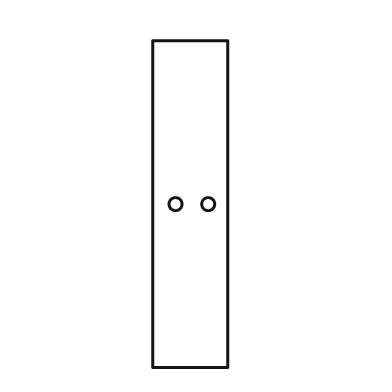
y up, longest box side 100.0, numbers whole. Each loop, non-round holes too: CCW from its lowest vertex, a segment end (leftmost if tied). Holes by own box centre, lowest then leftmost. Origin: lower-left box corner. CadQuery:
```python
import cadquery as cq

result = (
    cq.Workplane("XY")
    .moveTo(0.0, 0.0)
    .lineTo(23.0, 0.0)
    .lineTo(23.0, 100.0)
    .lineTo(0.0, 100.0)
    .close()
    .moveTo(7.0, 50.0)
    .circle(2.0)
    .moveTo(17.0, 50.0)
    .circle(2.0)
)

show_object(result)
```